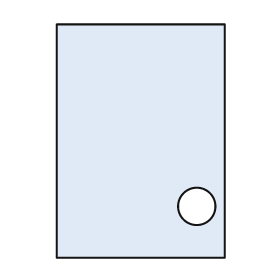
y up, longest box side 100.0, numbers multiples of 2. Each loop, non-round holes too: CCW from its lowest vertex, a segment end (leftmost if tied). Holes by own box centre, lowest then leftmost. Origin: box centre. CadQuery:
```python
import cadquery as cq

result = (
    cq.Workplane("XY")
    .moveTo(-36.0, -50.0)
    .lineTo(36.0, -50.0)
    .lineTo(36.0, 50.0)
    .lineTo(-36.0, 50.0)
    .close()
    .moveTo(24.0, -28.0)
    .circle(8.0)
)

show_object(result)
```